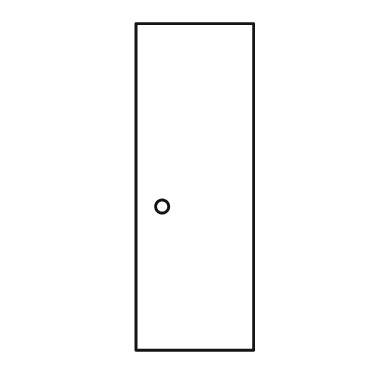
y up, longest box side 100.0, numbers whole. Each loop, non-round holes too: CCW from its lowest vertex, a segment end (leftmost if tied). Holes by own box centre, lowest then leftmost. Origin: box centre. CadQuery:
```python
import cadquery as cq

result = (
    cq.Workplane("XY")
    .moveTo(-18.0, -50.0)
    .lineTo(18.0, -50.0)
    .lineTo(18.0, 50.0)
    .lineTo(-18.0, 50.0)
    .close()
    .moveTo(-10.0, -6.0)
    .circle(2.0)
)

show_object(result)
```